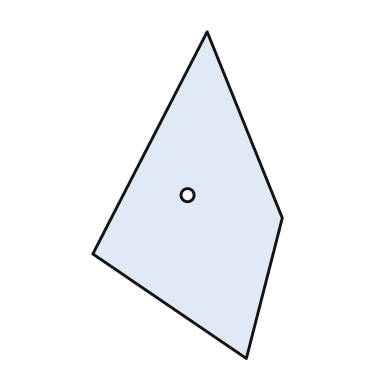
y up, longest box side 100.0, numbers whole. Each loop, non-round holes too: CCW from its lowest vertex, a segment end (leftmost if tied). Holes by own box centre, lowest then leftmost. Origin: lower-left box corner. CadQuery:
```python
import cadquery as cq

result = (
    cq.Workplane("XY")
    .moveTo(47.0, 0.0)
    .lineTo(58.0, 43.0)
    .lineTo(35.0, 100.0)
    .lineTo(0.0, 32.0)
    .close()
    .moveTo(29.0, 50.0)
    .circle(2.0)
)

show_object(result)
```